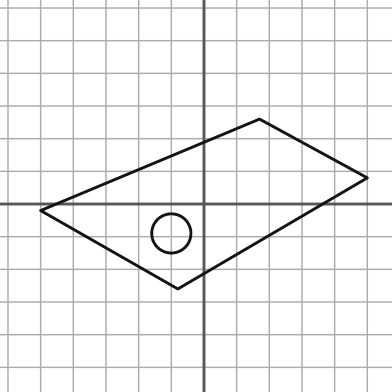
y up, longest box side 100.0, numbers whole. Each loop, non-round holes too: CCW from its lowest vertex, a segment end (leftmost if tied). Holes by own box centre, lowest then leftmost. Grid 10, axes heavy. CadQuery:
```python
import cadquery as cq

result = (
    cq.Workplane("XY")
    .moveTo(-8.0, -26.0)
    .lineTo(50.0, 8.0)
    .lineTo(17.0, 26.0)
    .lineTo(-50.0, -2.0)
    .close()
    .moveTo(-10.0, -9.0)
    .circle(6.0)
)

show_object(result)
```